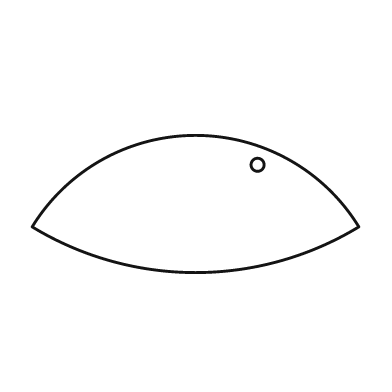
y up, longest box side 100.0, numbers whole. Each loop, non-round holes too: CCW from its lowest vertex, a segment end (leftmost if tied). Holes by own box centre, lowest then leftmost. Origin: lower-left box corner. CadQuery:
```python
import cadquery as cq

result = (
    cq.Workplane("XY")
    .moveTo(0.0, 14.0)
    .threePointArc((50.0, 0.0), (100.0, 14.0))
    .threePointArc((50.0, 42.0), (0.0, 14.0))
    .close()
    .moveTo(69.0, 33.0)
    .circle(2.0)
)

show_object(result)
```